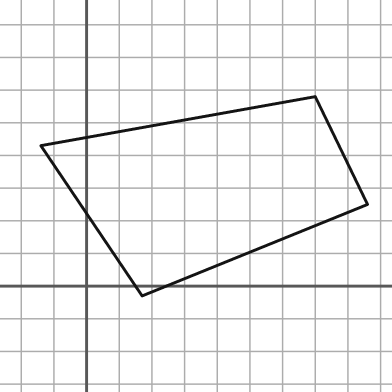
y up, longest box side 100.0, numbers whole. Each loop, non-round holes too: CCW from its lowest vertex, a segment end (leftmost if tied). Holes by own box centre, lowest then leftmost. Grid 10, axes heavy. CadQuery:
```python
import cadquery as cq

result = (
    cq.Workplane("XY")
    .moveTo(17.0, -3.0)
    .lineTo(86.0, 25.0)
    .lineTo(70.0, 58.0)
    .lineTo(-14.0, 43.0)
    .close()
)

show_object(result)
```